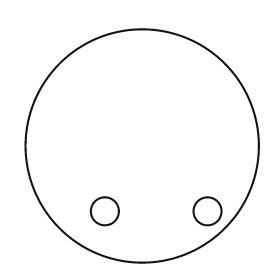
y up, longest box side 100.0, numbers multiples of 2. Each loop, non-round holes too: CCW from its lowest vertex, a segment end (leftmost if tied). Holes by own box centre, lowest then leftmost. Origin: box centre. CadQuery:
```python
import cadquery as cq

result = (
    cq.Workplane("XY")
    .moveTo(0.0, 0.0)
    .circle(50.0)
    .moveTo(-16.0, -28.0)
    .circle(6.0)
    .moveTo(28.0, -28.0)
    .circle(6.0)
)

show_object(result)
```